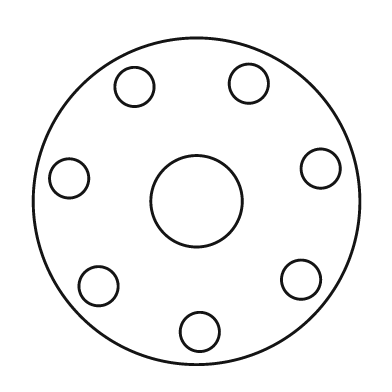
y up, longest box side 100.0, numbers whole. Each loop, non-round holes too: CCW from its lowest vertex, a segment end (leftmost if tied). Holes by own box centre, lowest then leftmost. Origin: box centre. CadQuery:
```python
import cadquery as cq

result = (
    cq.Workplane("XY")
    .moveTo(0.0, 0.0)
    .circle(50.0)
    .moveTo(1.0, -40.0)
    .circle(6.0)
    .moveTo(-30.0, -26.0)
    .circle(6.0)
    .moveTo(32.0, -24.0)
    .circle(6.0)
    .moveTo(0.0, 0.0)
    .circle(14.0)
    .moveTo(-39.0, 7.0)
    .circle(6.0)
    .moveTo(38.0, 10.0)
    .circle(6.0)
    .moveTo(-19.0, 35.0)
    .circle(6.0)
    .moveTo(16.0, 36.0)
    .circle(6.0)
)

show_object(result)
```